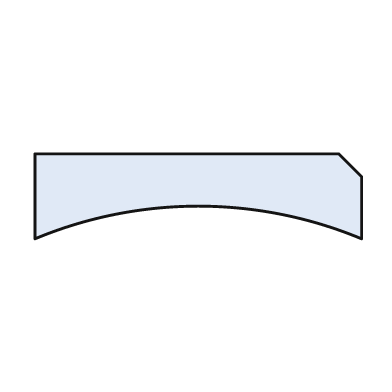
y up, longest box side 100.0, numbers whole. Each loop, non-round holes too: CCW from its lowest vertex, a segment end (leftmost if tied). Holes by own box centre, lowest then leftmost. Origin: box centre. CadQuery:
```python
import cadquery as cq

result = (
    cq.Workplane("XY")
    .moveTo(-50.0, -13.0)
    .threePointArc((0.0, -3.0), (50.0, -13.0))
    .lineTo(50.0, 6.0)
    .lineTo(43.0, 13.0)
    .lineTo(-50.0, 13.0)
    .close()
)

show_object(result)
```